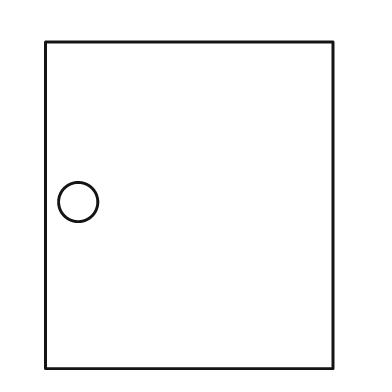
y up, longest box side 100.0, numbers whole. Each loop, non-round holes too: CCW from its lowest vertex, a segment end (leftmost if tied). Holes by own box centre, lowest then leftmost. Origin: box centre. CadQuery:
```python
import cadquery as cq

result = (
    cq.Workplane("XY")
    .moveTo(-44.0, -50.0)
    .lineTo(44.0, -50.0)
    .lineTo(44.0, 50.0)
    .lineTo(-44.0, 50.0)
    .close()
    .moveTo(-34.0, 1.0)
    .circle(6.0)
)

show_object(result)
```